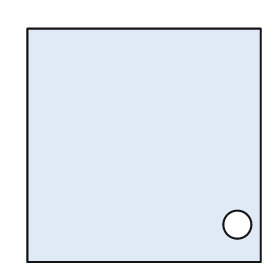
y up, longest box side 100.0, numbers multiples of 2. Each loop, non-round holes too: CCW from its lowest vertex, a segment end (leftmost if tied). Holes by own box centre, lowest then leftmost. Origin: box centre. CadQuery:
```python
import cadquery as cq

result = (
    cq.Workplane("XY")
    .moveTo(-50.0, -50.0)
    .lineTo(50.0, -50.0)
    .lineTo(50.0, 50.0)
    .lineTo(-50.0, 50.0)
    .close()
    .moveTo(40.0, -34.0)
    .circle(6.0)
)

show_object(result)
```